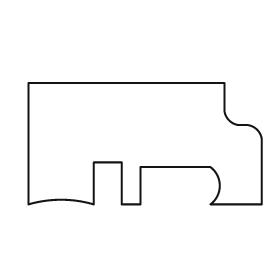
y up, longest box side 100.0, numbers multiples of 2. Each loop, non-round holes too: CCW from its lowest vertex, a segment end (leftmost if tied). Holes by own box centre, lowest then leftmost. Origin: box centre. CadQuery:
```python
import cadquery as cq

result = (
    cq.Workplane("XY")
    .moveTo(-50.0, -26.0)
    .threePointArc((-36.0, -24.0), (-22.0, -26.0))
    .lineTo(-22.0, -8.0)
    .lineTo(-10.0, -8.0)
    .lineTo(-10.0, -26.0)
    .lineTo(-2.0, -26.0)
    .lineTo(-2.0, -10.0)
    .lineTo(28.0, -10.0)
    .threePointArc((32.0, -18.0), (28.0, -26.0))
    .lineTo(50.0, -26.0)
    .lineTo(50.0, 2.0)
    .threePointArc((48.0, 6.0), (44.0, 8.0))
    .lineTo(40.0, 8.0)
    .threePointArc((36.0, 10.0), (34.0, 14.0))
    .lineTo(34.0, 26.0)
    .lineTo(-50.0, 26.0)
    .close()
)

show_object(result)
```